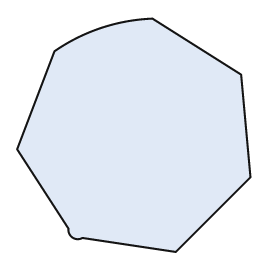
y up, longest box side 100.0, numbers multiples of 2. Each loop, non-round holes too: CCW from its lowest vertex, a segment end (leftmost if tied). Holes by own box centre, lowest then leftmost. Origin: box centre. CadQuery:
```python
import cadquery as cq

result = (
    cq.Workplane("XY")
    .moveTo(18.0, -50.0)
    .lineTo(50.0, -18.0)
    .lineTo(46.0, 26.0)
    .lineTo(8.0, 50.0)
    .threePointArc((-14.0, 46.0), (-34.0, 36.0))
    .lineTo(-50.0, -6.0)
    .lineTo(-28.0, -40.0)
    .threePointArc((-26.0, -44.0), (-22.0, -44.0))
    .close()
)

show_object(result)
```